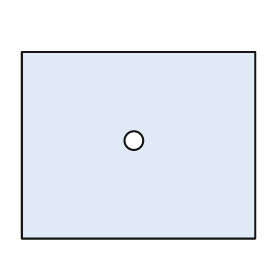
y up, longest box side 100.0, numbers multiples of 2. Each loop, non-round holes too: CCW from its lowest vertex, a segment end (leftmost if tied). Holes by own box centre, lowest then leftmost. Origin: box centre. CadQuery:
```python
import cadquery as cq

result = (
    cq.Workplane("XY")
    .moveTo(-50.0, -40.0)
    .lineTo(50.0, -40.0)
    .lineTo(50.0, 40.0)
    .lineTo(-50.0, 40.0)
    .close()
    .moveTo(-2.0, 2.0)
    .circle(4.0)
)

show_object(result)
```